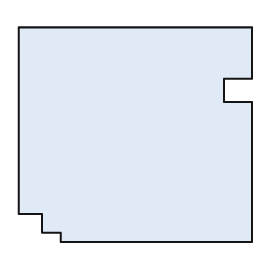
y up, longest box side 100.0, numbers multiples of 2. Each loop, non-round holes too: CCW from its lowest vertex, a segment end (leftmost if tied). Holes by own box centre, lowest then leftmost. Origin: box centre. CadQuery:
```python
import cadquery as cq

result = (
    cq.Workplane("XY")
    .moveTo(-32.0, -46.0)
    .lineTo(50.0, -46.0)
    .lineTo(50.0, 14.0)
    .lineTo(38.0, 14.0)
    .lineTo(38.0, 24.0)
    .lineTo(50.0, 24.0)
    .lineTo(50.0, 46.0)
    .lineTo(-50.0, 46.0)
    .lineTo(-50.0, -34.0)
    .lineTo(-40.0, -34.0)
    .lineTo(-40.0, -42.0)
    .lineTo(-32.0, -42.0)
    .close()
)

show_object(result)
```